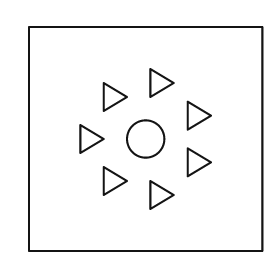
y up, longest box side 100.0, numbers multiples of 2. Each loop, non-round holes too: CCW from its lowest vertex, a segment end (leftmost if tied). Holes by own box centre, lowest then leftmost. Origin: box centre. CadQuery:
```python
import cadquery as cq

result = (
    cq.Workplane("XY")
    .moveTo(-50.0, -48.0)
    .lineTo(50.0, -48.0)
    .lineTo(50.0, 48.0)
    .lineTo(-50.0, 48.0)
    .close()
    .moveTo(2.0, -30.0)
    .lineTo(12.0, -24.0)
    .lineTo(2.0, -18.0)
    .close()
    .moveTo(-18.0, -24.0)
    .lineTo(-8.0, -18.0)
    .lineTo(-18.0, -12.0)
    .close()
    .moveTo(18.0, -16.0)
    .lineTo(28.0, -10.0)
    .lineTo(18.0, -4.0)
    .close()
    .moveTo(-28.0, -6.0)
    .lineTo(-18.0, 0.0)
    .lineTo(-28.0, 6.0)
    .close()
    .moveTo(0.0, 0.0)
    .circle(8.0)
    .moveTo(18.0, 4.0)
    .lineTo(28.0, 10.0)
    .lineTo(18.0, 16.0)
    .close()
    .moveTo(-18.0, 12.0)
    .lineTo(-8.0, 18.0)
    .lineTo(-18.0, 24.0)
    .close()
    .moveTo(2.0, 18.0)
    .lineTo(12.0, 24.0)
    .lineTo(2.0, 30.0)
    .close()
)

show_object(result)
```